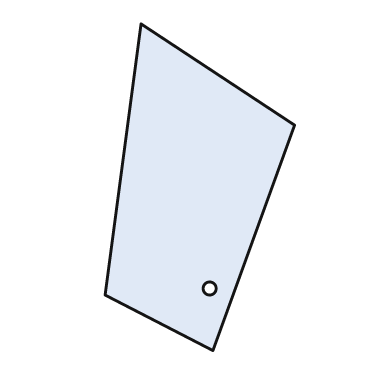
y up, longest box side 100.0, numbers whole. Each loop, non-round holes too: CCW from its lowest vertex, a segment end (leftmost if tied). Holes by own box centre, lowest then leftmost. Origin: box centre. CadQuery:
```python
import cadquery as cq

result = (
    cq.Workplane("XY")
    .moveTo(4.0, -50.0)
    .lineTo(29.0, 19.0)
    .lineTo(-18.0, 50.0)
    .lineTo(-29.0, -33.0)
    .close()
    .moveTo(3.0, -31.0)
    .circle(2.0)
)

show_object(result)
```